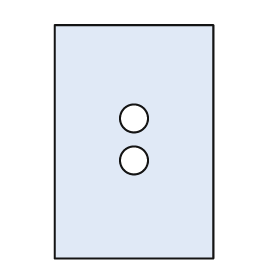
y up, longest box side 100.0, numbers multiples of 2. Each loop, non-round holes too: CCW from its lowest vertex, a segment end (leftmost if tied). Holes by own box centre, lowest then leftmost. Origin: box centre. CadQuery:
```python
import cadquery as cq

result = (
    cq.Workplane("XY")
    .moveTo(-34.0, -50.0)
    .lineTo(34.0, -50.0)
    .lineTo(34.0, 50.0)
    .lineTo(-34.0, 50.0)
    .close()
    .moveTo(0.0, -8.0)
    .circle(6.0)
    .moveTo(0.0, 10.0)
    .circle(6.0)
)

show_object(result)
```